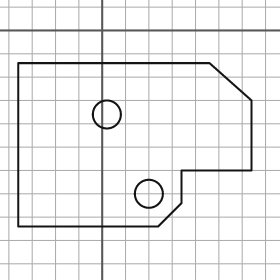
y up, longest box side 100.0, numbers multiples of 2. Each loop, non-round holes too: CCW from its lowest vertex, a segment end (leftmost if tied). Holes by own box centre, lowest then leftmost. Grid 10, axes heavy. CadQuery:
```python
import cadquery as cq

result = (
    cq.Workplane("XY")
    .moveTo(-36.0, -84.0)
    .lineTo(24.0, -84.0)
    .lineTo(34.0, -74.0)
    .lineTo(34.0, -60.0)
    .lineTo(64.0, -60.0)
    .lineTo(64.0, -30.0)
    .lineTo(46.0, -14.0)
    .lineTo(-36.0, -14.0)
    .close()
    .moveTo(20.0, -70.0)
    .circle(6.0)
    .moveTo(2.0, -36.0)
    .circle(6.0)
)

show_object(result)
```